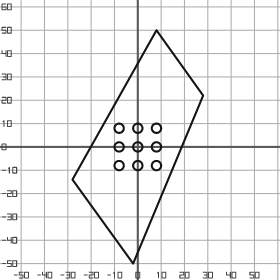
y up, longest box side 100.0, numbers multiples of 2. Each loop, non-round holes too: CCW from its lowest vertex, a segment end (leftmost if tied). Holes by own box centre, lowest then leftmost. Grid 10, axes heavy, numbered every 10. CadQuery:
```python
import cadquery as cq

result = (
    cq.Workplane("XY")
    .moveTo(-2.0, -50.0)
    .lineTo(28.0, 22.0)
    .lineTo(8.0, 50.0)
    .lineTo(-28.0, -14.0)
    .close()
    .moveTo(-8.0, -8.0)
    .circle(2.0)
    .moveTo(0.0, -8.0)
    .circle(2.0)
    .moveTo(8.0, -8.0)
    .circle(2.0)
    .moveTo(-8.0, 0.0)
    .circle(2.0)
    .moveTo(0.0, 0.0)
    .circle(2.0)
    .moveTo(8.0, 0.0)
    .circle(2.0)
    .moveTo(-8.0, 8.0)
    .circle(2.0)
    .moveTo(0.0, 8.0)
    .circle(2.0)
    .moveTo(8.0, 8.0)
    .circle(2.0)
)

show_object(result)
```